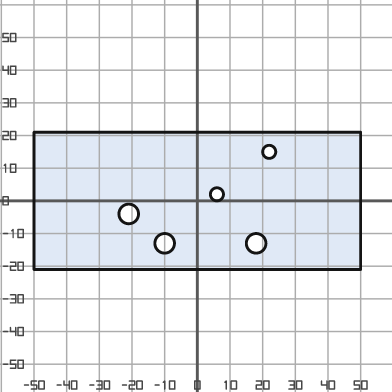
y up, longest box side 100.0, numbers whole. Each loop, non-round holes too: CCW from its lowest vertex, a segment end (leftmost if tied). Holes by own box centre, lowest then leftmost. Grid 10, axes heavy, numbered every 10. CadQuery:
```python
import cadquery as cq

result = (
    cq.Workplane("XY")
    .moveTo(-50.0, -21.0)
    .lineTo(50.0, -21.0)
    .lineTo(50.0, 21.0)
    .lineTo(-50.0, 21.0)
    .close()
    .moveTo(-10.0, -13.0)
    .circle(3.0)
    .moveTo(18.0, -13.0)
    .circle(3.0)
    .moveTo(-21.0, -4.0)
    .circle(3.0)
    .moveTo(6.0, 2.0)
    .circle(2.0)
    .moveTo(22.0, 15.0)
    .circle(2.0)
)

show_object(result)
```